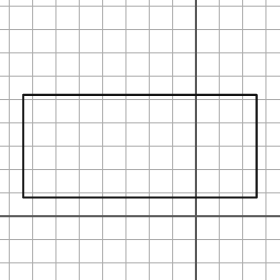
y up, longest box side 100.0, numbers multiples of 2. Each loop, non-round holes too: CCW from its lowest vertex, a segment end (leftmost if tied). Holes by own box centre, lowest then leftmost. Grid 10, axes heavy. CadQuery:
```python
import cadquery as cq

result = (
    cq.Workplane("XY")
    .moveTo(-74.0, 8.0)
    .lineTo(26.0, 8.0)
    .lineTo(26.0, 52.0)
    .lineTo(-74.0, 52.0)
    .close()
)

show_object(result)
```